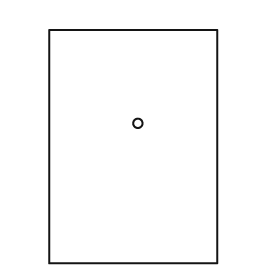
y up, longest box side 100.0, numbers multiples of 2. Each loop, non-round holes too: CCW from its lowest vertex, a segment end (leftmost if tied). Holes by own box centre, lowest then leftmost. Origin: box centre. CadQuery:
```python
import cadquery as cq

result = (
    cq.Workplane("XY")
    .moveTo(-36.0, -50.0)
    .lineTo(36.0, -50.0)
    .lineTo(36.0, 50.0)
    .lineTo(-36.0, 50.0)
    .close()
    .moveTo(2.0, 10.0)
    .circle(2.0)
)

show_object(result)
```